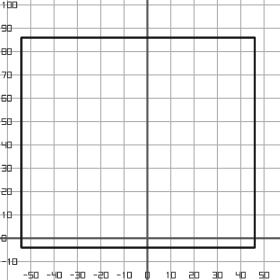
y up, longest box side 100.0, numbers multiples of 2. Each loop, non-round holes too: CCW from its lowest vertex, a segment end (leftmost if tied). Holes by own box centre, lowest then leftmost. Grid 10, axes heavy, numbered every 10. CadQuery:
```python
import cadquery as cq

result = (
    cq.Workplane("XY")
    .moveTo(-54.0, -4.0)
    .lineTo(46.0, -4.0)
    .lineTo(46.0, 86.0)
    .lineTo(-54.0, 86.0)
    .close()
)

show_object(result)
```